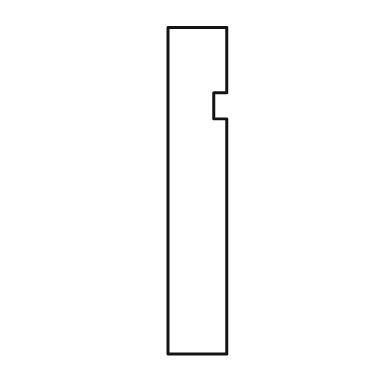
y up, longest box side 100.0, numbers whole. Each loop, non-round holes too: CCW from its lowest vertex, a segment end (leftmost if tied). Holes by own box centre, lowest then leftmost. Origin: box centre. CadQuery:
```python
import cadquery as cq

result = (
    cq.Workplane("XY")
    .moveTo(-9.0, -50.0)
    .lineTo(9.0, -50.0)
    .lineTo(9.0, 22.0)
    .lineTo(5.0, 22.0)
    .lineTo(5.0, 30.0)
    .lineTo(9.0, 30.0)
    .lineTo(9.0, 50.0)
    .lineTo(-9.0, 50.0)
    .close()
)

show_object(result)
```